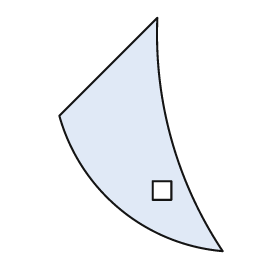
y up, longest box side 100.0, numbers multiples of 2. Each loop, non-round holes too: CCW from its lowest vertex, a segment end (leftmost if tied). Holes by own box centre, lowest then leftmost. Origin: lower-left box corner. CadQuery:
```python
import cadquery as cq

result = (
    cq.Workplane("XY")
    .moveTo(70.0, 0.0)
    .threePointArc((48.0, 48.0), (42.0, 100.0))
    .lineTo(0.0, 58.0)
    .threePointArc((26.0, 18.0), (70.0, 0.0))
    .close()
    .moveTo(40.0, 22.0)
    .lineTo(48.0, 22.0)
    .lineTo(48.0, 30.0)
    .lineTo(40.0, 30.0)
    .close()
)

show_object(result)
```